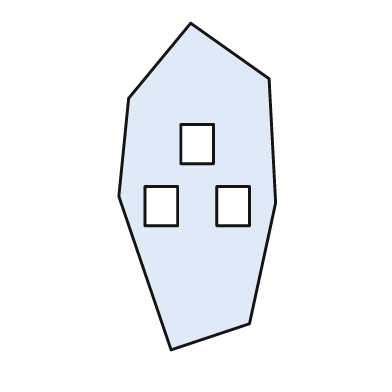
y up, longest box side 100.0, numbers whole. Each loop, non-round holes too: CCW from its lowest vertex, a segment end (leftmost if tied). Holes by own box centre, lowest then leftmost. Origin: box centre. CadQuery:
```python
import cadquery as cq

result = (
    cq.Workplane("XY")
    .moveTo(-8.0, -50.0)
    .lineTo(16.0, -42.0)
    .lineTo(24.0, -5.0)
    .lineTo(22.0, 33.0)
    .lineTo(-2.0, 50.0)
    .lineTo(-21.0, 27.0)
    .lineTo(-24.0, -3.0)
    .close()
    .moveTo(-16.0, -12.0)
    .lineTo(-6.0, -12.0)
    .lineTo(-6.0, 0.0)
    .lineTo(-16.0, 0.0)
    .close()
    .moveTo(6.0, -12.0)
    .lineTo(16.0, -12.0)
    .lineTo(16.0, 0.0)
    .lineTo(6.0, 0.0)
    .close()
    .moveTo(-5.0, 7.0)
    .lineTo(5.0, 7.0)
    .lineTo(5.0, 19.0)
    .lineTo(-5.0, 19.0)
    .close()
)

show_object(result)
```